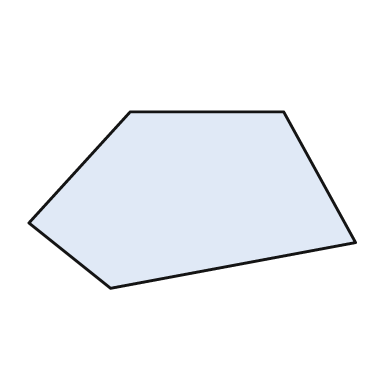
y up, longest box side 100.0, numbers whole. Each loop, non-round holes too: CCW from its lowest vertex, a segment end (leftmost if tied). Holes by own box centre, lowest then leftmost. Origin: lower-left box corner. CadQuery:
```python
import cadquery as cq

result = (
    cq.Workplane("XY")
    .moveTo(25.0, 0.0)
    .lineTo(100.0, 14.0)
    .lineTo(78.0, 54.0)
    .lineTo(31.0, 54.0)
    .lineTo(0.0, 20.0)
    .close()
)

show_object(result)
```